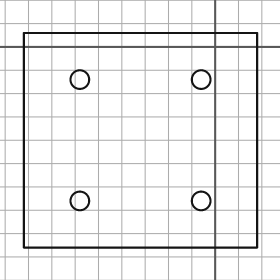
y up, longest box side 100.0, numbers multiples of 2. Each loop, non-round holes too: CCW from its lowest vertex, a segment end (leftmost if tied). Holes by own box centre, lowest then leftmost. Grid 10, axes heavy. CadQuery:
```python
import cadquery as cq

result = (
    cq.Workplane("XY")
    .moveTo(-82.0, -86.0)
    .lineTo(18.0, -86.0)
    .lineTo(18.0, 6.0)
    .lineTo(-82.0, 6.0)
    .close()
    .moveTo(-58.0, -66.0)
    .circle(4.0)
    .moveTo(-6.0, -66.0)
    .circle(4.0)
    .moveTo(-58.0, -14.0)
    .circle(4.0)
    .moveTo(-6.0, -14.0)
    .circle(4.0)
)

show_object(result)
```